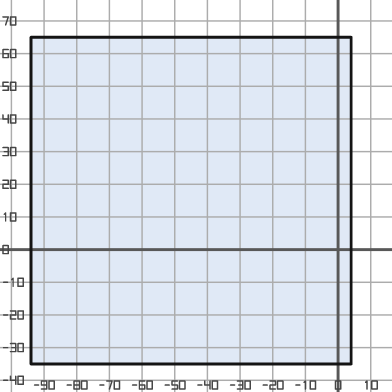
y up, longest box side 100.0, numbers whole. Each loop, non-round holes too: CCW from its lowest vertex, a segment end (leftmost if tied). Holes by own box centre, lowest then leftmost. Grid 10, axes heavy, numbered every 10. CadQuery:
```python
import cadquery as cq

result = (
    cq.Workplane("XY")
    .moveTo(-94.0, -35.0)
    .lineTo(4.0, -35.0)
    .lineTo(4.0, 65.0)
    .lineTo(-94.0, 65.0)
    .close()
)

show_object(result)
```